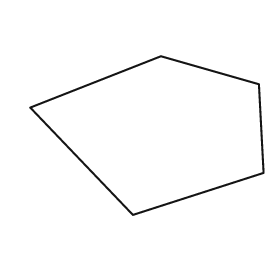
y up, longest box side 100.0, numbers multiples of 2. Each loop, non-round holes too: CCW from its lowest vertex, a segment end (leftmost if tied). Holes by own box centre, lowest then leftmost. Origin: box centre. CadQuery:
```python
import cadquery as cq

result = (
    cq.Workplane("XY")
    .moveTo(-6.0, -34.0)
    .lineTo(50.0, -16.0)
    .lineTo(48.0, 22.0)
    .lineTo(6.0, 34.0)
    .lineTo(-50.0, 12.0)
    .close()
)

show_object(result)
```